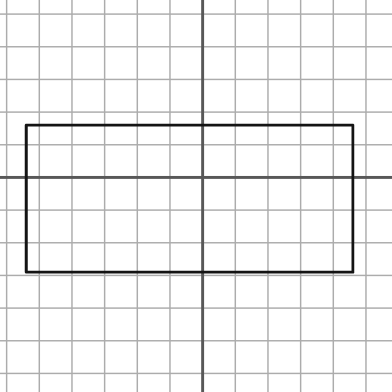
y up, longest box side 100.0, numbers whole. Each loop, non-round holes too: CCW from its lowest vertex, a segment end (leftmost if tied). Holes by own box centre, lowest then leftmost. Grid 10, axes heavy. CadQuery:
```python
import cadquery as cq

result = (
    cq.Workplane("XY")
    .moveTo(-54.0, -29.0)
    .lineTo(46.0, -29.0)
    .lineTo(46.0, 16.0)
    .lineTo(-54.0, 16.0)
    .close()
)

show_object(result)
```